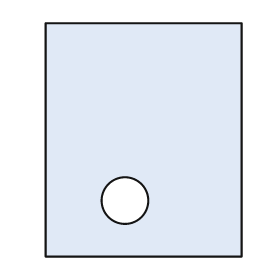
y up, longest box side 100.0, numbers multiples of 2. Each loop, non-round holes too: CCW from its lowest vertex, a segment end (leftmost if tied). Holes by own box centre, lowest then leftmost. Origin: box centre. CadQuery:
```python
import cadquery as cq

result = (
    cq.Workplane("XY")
    .moveTo(-42.0, -50.0)
    .lineTo(42.0, -50.0)
    .lineTo(42.0, 50.0)
    .lineTo(-42.0, 50.0)
    .close()
    .moveTo(-8.0, -26.0)
    .circle(10.0)
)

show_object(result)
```